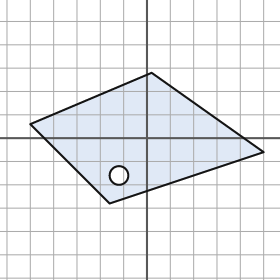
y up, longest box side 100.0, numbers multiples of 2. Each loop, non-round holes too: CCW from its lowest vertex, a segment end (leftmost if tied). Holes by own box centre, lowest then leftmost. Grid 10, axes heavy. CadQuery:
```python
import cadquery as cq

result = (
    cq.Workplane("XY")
    .moveTo(-16.0, -28.0)
    .lineTo(50.0, -6.0)
    .lineTo(2.0, 28.0)
    .lineTo(-50.0, 6.0)
    .close()
    .moveTo(-12.0, -16.0)
    .circle(4.0)
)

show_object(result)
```